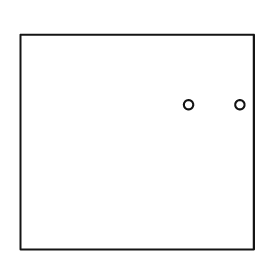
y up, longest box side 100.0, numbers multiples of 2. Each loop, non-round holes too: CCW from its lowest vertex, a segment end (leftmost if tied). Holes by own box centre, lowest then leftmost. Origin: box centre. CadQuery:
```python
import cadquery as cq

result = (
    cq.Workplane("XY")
    .moveTo(-50.0, -46.0)
    .lineTo(50.0, -46.0)
    .lineTo(50.0, 46.0)
    .lineTo(-50.0, 46.0)
    .close()
    .moveTo(22.0, 16.0)
    .circle(2.0)
    .moveTo(44.0, 16.0)
    .circle(2.0)
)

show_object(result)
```